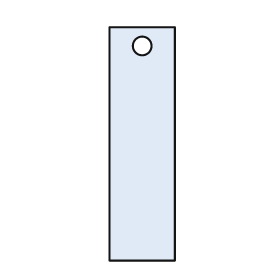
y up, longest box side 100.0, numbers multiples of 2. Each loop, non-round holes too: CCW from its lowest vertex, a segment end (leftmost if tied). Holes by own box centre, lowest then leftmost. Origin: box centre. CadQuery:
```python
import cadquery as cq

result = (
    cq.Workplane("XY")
    .moveTo(-14.0, -50.0)
    .lineTo(14.0, -50.0)
    .lineTo(14.0, 50.0)
    .lineTo(-14.0, 50.0)
    .close()
    .moveTo(0.0, 42.0)
    .circle(4.0)
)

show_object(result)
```